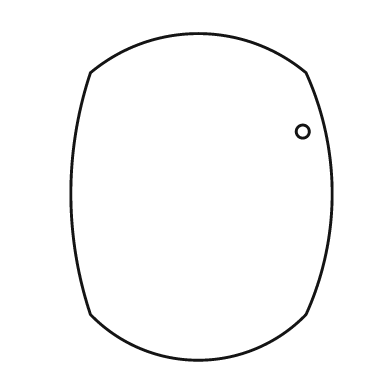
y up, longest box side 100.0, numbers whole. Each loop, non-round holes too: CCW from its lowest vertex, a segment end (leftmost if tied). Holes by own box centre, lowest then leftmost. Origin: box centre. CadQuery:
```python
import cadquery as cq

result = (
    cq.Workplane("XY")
    .moveTo(-34.0, -36.0)
    .threePointArc((-1.0, -50.0), (32.0, -36.0))
    .threePointArc((40.0, 1.0), (32.0, 38.0))
    .threePointArc((-1.0, 50.0), (-34.0, 38.0))
    .threePointArc((-40.0, 1.0), (-34.0, -36.0))
    .close()
    .moveTo(31.0, 20.0)
    .circle(2.0)
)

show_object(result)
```